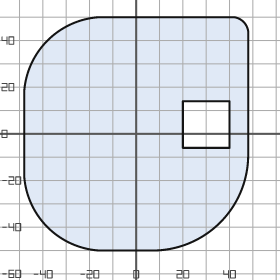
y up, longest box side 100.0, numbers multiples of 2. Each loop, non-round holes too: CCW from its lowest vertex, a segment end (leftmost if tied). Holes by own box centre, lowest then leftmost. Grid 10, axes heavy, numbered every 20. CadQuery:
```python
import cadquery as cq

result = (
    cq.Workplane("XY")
    .moveTo(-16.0, -50.0)
    .lineTo(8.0, -50.0)
    .threePointArc((36.0, -38.0), (48.0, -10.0))
    .lineTo(48.0, 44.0)
    .threePointArc((46.0, 48.0), (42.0, 50.0))
    .lineTo(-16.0, 50.0)
    .threePointArc((-38.0, 40.0), (-48.0, 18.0))
    .lineTo(-48.0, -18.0)
    .threePointArc((-38.0, -40.0), (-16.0, -50.0))
    .close()
    .moveTo(20.0, -6.0)
    .lineTo(40.0, -6.0)
    .lineTo(40.0, 14.0)
    .lineTo(20.0, 14.0)
    .close()
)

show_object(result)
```